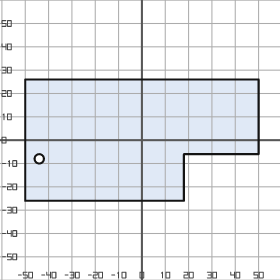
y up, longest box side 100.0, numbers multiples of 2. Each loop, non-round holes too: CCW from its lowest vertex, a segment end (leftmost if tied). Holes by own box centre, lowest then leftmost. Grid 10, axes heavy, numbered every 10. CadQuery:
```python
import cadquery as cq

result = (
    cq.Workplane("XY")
    .moveTo(-50.0, -26.0)
    .lineTo(18.0, -26.0)
    .lineTo(18.0, -6.0)
    .lineTo(50.0, -6.0)
    .lineTo(50.0, 26.0)
    .lineTo(-50.0, 26.0)
    .close()
    .moveTo(-44.0, -8.0)
    .circle(2.0)
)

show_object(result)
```